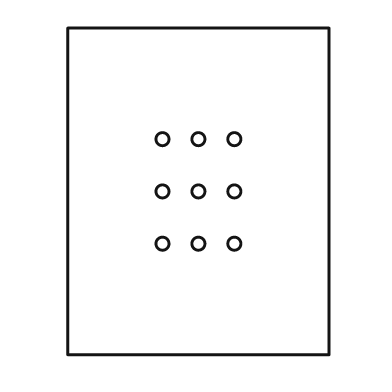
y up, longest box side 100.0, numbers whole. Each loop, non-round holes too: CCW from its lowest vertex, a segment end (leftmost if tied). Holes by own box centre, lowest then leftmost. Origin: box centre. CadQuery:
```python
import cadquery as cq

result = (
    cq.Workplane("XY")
    .moveTo(-40.0, -50.0)
    .lineTo(40.0, -50.0)
    .lineTo(40.0, 50.0)
    .lineTo(-40.0, 50.0)
    .close()
    .moveTo(-11.0, -16.0)
    .circle(2.0)
    .moveTo(0.0, -16.0)
    .circle(2.0)
    .moveTo(11.0, -16.0)
    .circle(2.0)
    .moveTo(-11.0, 0.0)
    .circle(2.0)
    .moveTo(0.0, 0.0)
    .circle(2.0)
    .moveTo(11.0, 0.0)
    .circle(2.0)
    .moveTo(-11.0, 16.0)
    .circle(2.0)
    .moveTo(0.0, 16.0)
    .circle(2.0)
    .moveTo(11.0, 16.0)
    .circle(2.0)
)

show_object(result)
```